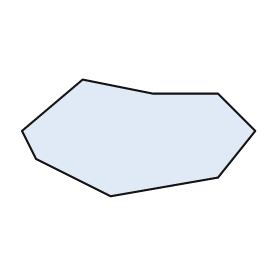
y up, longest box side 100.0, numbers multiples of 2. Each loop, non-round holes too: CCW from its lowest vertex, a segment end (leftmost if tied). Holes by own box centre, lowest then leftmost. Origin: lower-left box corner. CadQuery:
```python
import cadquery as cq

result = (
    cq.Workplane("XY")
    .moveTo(38.0, 0.0)
    .lineTo(84.0, 8.0)
    .lineTo(100.0, 28.0)
    .lineTo(84.0, 44.0)
    .lineTo(56.0, 44.0)
    .lineTo(26.0, 50.0)
    .lineTo(0.0, 28.0)
    .lineTo(6.0, 16.0)
    .close()
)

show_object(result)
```